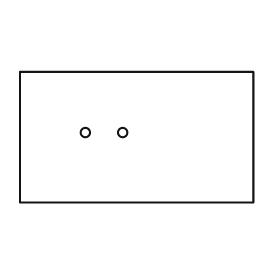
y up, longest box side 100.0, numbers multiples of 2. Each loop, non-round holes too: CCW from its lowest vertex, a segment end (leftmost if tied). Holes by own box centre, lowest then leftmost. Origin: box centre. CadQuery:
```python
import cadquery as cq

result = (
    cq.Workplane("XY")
    .moveTo(-50.0, -28.0)
    .lineTo(50.0, -28.0)
    .lineTo(50.0, 28.0)
    .lineTo(-50.0, 28.0)
    .close()
    .moveTo(-22.0, 2.0)
    .circle(2.0)
    .moveTo(-6.0, 2.0)
    .circle(2.0)
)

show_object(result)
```